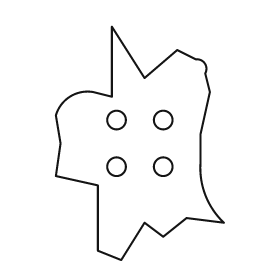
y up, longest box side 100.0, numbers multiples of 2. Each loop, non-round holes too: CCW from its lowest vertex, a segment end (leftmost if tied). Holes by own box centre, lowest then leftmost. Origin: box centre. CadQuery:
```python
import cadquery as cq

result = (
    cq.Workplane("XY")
    .moveTo(-8.0, -50.0)
    .lineTo(2.0, -34.0)
    .lineTo(10.0, -40.0)
    .lineTo(20.0, -32.0)
    .lineTo(36.0, -34.0)
    .threePointArc((28.0, -22.0), (26.0, -8.0))
    .lineTo(26.0, 4.0)
    .lineTo(30.0, 22.0)
    .lineTo(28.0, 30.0)
    .threePointArc((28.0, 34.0), (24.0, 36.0))
    .lineTo(16.0, 40.0)
    .lineTo(2.0, 28.0)
    .lineTo(-12.0, 50.0)
    .lineTo(-12.0, 20.0)
    .lineTo(-20.0, 22.0)
    .threePointArc((-30.0, 20.0), (-36.0, 12.0))
    .lineTo(-34.0, 0.0)
    .lineTo(-36.0, -14.0)
    .lineTo(-18.0, -18.0)
    .lineTo(-18.0, -46.0)
    .close()
    .moveTo(-10.0, -10.0)
    .circle(4.0)
    .moveTo(10.0, -10.0)
    .circle(4.0)
    .moveTo(-10.0, 10.0)
    .circle(4.0)
    .moveTo(10.0, 10.0)
    .circle(4.0)
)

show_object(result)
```